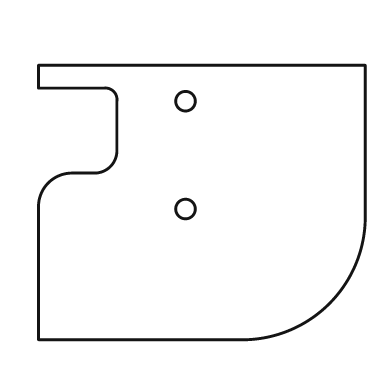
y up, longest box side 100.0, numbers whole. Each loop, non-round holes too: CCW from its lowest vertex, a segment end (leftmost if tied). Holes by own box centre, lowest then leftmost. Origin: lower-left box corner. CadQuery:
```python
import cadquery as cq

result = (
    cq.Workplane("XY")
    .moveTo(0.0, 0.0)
    .lineTo(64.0, 0.0)
    .threePointArc((89.0, 11.0), (100.0, 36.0))
    .lineTo(100.0, 84.0)
    .lineTo(0.0, 84.0)
    .lineTo(0.0, 77.0)
    .lineTo(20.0, 77.0)
    .threePointArc((23.0, 76.0), (24.0, 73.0))
    .lineTo(24.0, 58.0)
    .threePointArc((22.0, 53.0), (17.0, 51.0))
    .lineTo(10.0, 51.0)
    .threePointArc((3.0, 48.0), (0.0, 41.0))
    .close()
    .moveTo(45.0, 40.0)
    .circle(3.0)
    .moveTo(45.0, 73.0)
    .circle(3.0)
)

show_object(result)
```